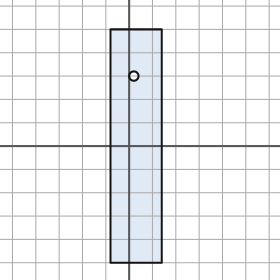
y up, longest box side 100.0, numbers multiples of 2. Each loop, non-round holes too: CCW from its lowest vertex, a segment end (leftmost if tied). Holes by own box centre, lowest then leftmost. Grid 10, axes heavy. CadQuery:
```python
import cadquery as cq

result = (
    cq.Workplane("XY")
    .moveTo(-8.0, -50.0)
    .lineTo(14.0, -50.0)
    .lineTo(14.0, 50.0)
    .lineTo(-8.0, 50.0)
    .close()
    .moveTo(2.0, 30.0)
    .circle(2.0)
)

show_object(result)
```